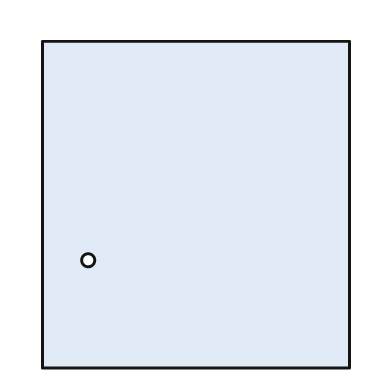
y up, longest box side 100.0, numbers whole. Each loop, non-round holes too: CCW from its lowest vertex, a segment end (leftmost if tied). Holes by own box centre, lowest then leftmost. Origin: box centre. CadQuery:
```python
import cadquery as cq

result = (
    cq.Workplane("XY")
    .moveTo(-47.0, -50.0)
    .lineTo(47.0, -50.0)
    .lineTo(47.0, 50.0)
    .lineTo(-47.0, 50.0)
    .close()
    .moveTo(-33.0, -17.0)
    .circle(2.0)
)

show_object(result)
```